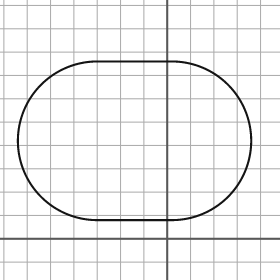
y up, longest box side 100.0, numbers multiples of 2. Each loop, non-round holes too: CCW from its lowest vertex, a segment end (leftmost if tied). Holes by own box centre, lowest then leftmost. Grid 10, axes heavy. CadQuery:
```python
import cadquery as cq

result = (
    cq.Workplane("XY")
    .moveTo(-30.0, 8.0)
    .lineTo(2.0, 8.0)
    .threePointArc((36.0, 42.0), (2.0, 76.0))
    .lineTo(-30.0, 76.0)
    .threePointArc((-64.0, 42.0), (-30.0, 8.0))
    .close()
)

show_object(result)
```